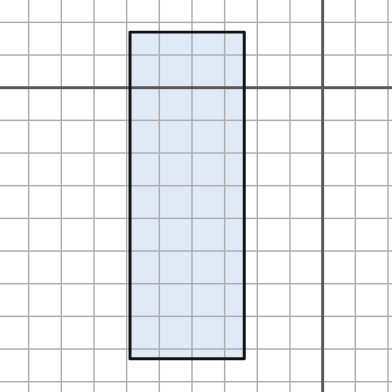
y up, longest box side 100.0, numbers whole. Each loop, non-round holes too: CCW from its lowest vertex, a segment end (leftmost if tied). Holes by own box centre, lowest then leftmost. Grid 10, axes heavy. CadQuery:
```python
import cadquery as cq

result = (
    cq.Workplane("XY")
    .moveTo(-59.0, -83.0)
    .lineTo(-24.0, -83.0)
    .lineTo(-24.0, 17.0)
    .lineTo(-59.0, 17.0)
    .close()
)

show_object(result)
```